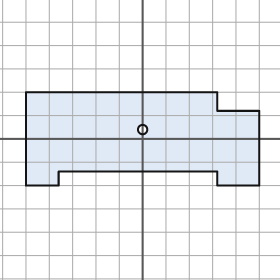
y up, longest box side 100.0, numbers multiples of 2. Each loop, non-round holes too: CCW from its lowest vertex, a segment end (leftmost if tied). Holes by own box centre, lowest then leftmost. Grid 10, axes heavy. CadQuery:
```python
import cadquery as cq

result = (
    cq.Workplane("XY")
    .moveTo(-50.0, -20.0)
    .lineTo(-36.0, -20.0)
    .lineTo(-36.0, -14.0)
    .lineTo(32.0, -14.0)
    .lineTo(32.0, -20.0)
    .lineTo(50.0, -20.0)
    .lineTo(50.0, 12.0)
    .lineTo(32.0, 12.0)
    .lineTo(32.0, 20.0)
    .lineTo(-50.0, 20.0)
    .close()
    .moveTo(0.0, 4.0)
    .circle(2.0)
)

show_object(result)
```